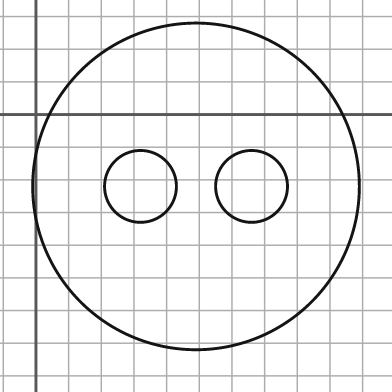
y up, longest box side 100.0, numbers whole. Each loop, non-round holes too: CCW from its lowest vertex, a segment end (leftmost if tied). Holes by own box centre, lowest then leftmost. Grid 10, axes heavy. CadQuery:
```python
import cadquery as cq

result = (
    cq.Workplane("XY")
    .moveTo(49.0, -22.0)
    .circle(50.0)
    .moveTo(32.0, -22.0)
    .circle(11.0)
    .moveTo(66.0, -22.0)
    .circle(11.0)
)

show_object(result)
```